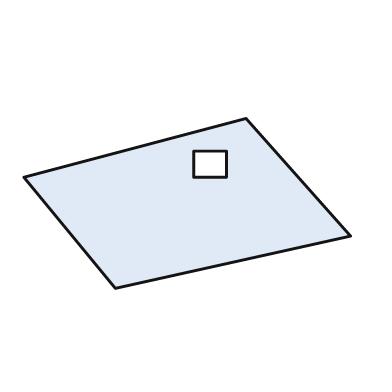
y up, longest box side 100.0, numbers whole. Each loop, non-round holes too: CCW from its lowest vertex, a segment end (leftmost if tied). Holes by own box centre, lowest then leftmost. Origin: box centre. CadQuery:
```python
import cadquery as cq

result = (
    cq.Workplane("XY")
    .moveTo(-22.0, -26.0)
    .lineTo(50.0, -10.0)
    .lineTo(18.0, 26.0)
    .lineTo(-50.0, 8.0)
    .close()
    .moveTo(2.0, 8.0)
    .lineTo(12.0, 8.0)
    .lineTo(12.0, 16.0)
    .lineTo(2.0, 16.0)
    .close()
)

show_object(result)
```